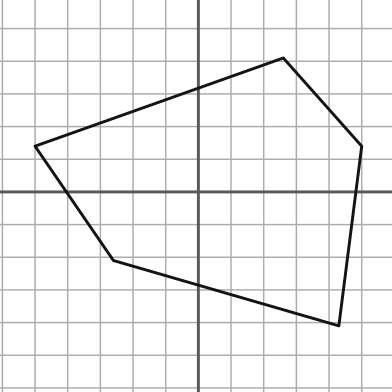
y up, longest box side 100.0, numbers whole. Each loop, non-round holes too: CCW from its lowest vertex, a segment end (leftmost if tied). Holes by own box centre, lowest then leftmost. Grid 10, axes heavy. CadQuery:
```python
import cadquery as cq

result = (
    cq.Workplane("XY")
    .moveTo(43.0, -41.0)
    .lineTo(50.0, 14.0)
    .lineTo(26.0, 41.0)
    .lineTo(-50.0, 14.0)
    .lineTo(-26.0, -21.0)
    .close()
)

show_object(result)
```